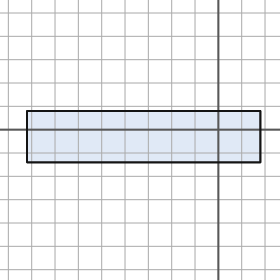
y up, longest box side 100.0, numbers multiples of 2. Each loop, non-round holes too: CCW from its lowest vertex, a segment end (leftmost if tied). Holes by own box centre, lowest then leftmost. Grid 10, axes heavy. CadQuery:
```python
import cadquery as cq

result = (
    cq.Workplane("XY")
    .moveTo(-82.0, -14.0)
    .lineTo(18.0, -14.0)
    .lineTo(18.0, 8.0)
    .lineTo(-82.0, 8.0)
    .close()
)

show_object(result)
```